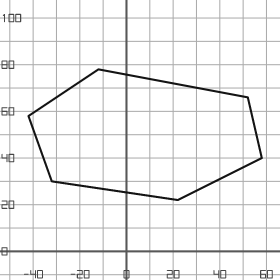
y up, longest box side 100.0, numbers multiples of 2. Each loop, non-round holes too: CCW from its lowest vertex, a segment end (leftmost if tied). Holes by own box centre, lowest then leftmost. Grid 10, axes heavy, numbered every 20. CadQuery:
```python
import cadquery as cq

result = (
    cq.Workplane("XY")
    .moveTo(22.0, 22.0)
    .lineTo(58.0, 40.0)
    .lineTo(52.0, 66.0)
    .lineTo(-12.0, 78.0)
    .lineTo(-42.0, 58.0)
    .lineTo(-32.0, 30.0)
    .close()
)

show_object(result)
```